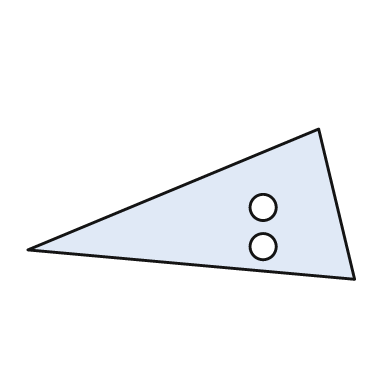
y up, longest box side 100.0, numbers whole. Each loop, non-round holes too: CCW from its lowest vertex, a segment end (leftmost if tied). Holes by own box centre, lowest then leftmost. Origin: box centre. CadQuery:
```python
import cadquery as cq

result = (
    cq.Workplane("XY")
    .moveTo(50.0, -23.0)
    .lineTo(39.0, 23.0)
    .lineTo(-50.0, -14.0)
    .close()
    .moveTo(22.0, -13.0)
    .circle(4.0)
    .moveTo(22.0, -1.0)
    .circle(4.0)
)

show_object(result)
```